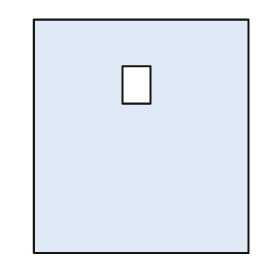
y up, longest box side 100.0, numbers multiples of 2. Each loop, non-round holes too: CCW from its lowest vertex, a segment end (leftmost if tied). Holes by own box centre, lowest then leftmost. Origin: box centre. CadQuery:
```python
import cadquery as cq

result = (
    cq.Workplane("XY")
    .moveTo(-46.0, -50.0)
    .lineTo(46.0, -50.0)
    .lineTo(46.0, 50.0)
    .lineTo(-46.0, 50.0)
    .close()
    .moveTo(-8.0, 14.0)
    .lineTo(4.0, 14.0)
    .lineTo(4.0, 30.0)
    .lineTo(-8.0, 30.0)
    .close()
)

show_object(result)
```